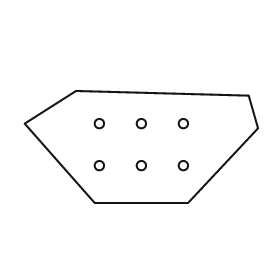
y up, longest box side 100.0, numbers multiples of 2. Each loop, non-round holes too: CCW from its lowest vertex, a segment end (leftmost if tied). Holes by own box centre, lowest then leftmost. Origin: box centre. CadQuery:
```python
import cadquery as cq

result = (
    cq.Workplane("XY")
    .moveTo(-20.0, -24.0)
    .lineTo(20.0, -24.0)
    .lineTo(50.0, 8.0)
    .lineTo(46.0, 22.0)
    .lineTo(-28.0, 24.0)
    .lineTo(-50.0, 10.0)
    .close()
    .moveTo(-18.0, -8.0)
    .circle(2.0)
    .moveTo(0.0, -8.0)
    .circle(2.0)
    .moveTo(18.0, -8.0)
    .circle(2.0)
    .moveTo(-18.0, 10.0)
    .circle(2.0)
    .moveTo(0.0, 10.0)
    .circle(2.0)
    .moveTo(18.0, 10.0)
    .circle(2.0)
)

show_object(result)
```